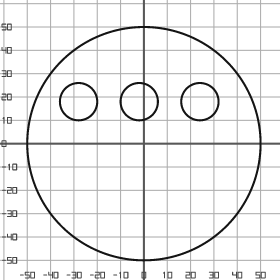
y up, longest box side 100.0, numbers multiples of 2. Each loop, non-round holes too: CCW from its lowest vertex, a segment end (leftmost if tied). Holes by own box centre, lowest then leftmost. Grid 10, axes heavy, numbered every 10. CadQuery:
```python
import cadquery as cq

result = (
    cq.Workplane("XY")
    .moveTo(0.0, 0.0)
    .circle(50.0)
    .moveTo(-28.0, 18.0)
    .circle(8.0)
    .moveTo(-2.0, 18.0)
    .circle(8.0)
    .moveTo(24.0, 18.0)
    .circle(8.0)
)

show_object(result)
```